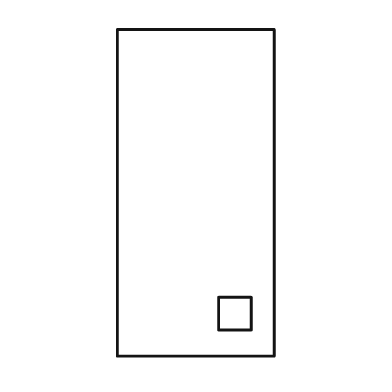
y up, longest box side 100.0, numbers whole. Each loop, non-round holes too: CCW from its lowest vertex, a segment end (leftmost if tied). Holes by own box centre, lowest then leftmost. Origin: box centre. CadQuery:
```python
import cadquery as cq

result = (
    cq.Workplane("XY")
    .moveTo(-24.0, -50.0)
    .lineTo(24.0, -50.0)
    .lineTo(24.0, 50.0)
    .lineTo(-24.0, 50.0)
    .close()
    .moveTo(7.0, -42.0)
    .lineTo(17.0, -42.0)
    .lineTo(17.0, -32.0)
    .lineTo(7.0, -32.0)
    .close()
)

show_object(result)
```